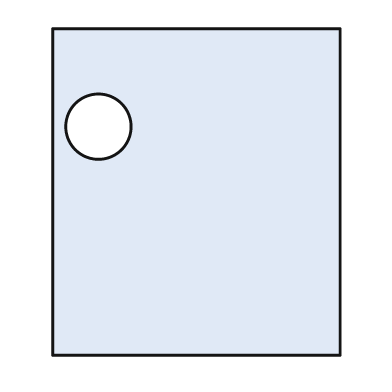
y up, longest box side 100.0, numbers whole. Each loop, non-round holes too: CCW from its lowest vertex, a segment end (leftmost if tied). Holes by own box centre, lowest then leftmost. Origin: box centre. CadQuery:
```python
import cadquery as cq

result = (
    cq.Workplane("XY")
    .moveTo(-44.0, -50.0)
    .lineTo(44.0, -50.0)
    .lineTo(44.0, 50.0)
    .lineTo(-44.0, 50.0)
    .close()
    .moveTo(-30.0, 20.0)
    .circle(10.0)
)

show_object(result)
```